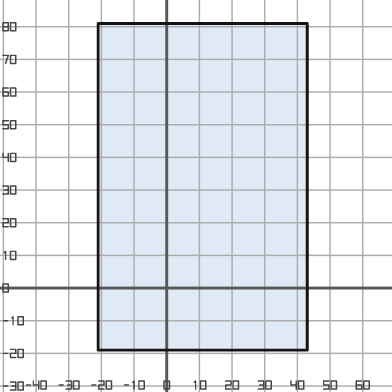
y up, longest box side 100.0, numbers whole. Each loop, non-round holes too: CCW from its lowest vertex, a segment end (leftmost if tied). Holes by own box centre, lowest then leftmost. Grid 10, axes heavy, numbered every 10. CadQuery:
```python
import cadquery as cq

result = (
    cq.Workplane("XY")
    .moveTo(-21.0, -19.0)
    .lineTo(43.0, -19.0)
    .lineTo(43.0, 81.0)
    .lineTo(-21.0, 81.0)
    .close()
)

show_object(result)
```